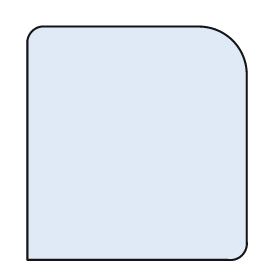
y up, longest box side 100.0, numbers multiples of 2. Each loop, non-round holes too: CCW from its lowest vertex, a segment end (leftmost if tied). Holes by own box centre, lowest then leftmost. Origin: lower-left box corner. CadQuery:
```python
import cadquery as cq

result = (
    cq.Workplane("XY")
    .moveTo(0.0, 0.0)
    .lineTo(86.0, 0.0)
    .threePointArc((92.0, 2.0), (94.0, 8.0))
    .lineTo(94.0, 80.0)
    .threePointArc((88.0, 94.0), (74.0, 100.0))
    .lineTo(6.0, 100.0)
    .threePointArc((2.0, 98.0), (0.0, 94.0))
    .close()
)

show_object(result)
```